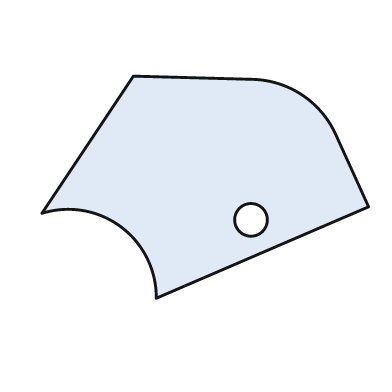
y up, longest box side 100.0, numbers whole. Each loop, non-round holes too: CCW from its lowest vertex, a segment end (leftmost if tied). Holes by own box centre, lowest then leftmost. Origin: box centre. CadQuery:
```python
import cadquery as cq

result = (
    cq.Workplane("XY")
    .moveTo(-15.0, -34.0)
    .lineTo(50.0, -6.0)
    .lineTo(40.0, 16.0)
    .threePointArc((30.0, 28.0), (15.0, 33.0))
    .lineTo(-22.0, 34.0)
    .lineTo(-50.0, -8.0)
    .threePointArc((-26.0, -12.0), (-15.0, -34.0))
    .close()
    .moveTo(14.0, -10.0)
    .circle(5.0)
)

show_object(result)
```